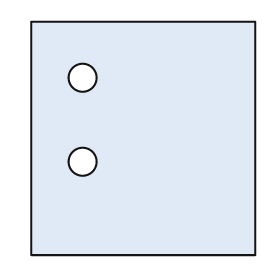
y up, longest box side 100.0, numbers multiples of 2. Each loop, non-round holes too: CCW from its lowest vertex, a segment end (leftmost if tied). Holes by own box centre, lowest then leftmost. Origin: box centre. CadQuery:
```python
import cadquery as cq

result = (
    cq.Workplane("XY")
    .moveTo(-48.0, -50.0)
    .lineTo(48.0, -50.0)
    .lineTo(48.0, 50.0)
    .lineTo(-48.0, 50.0)
    .close()
    .moveTo(-26.0, -10.0)
    .circle(6.0)
    .moveTo(-26.0, 26.0)
    .circle(6.0)
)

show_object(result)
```